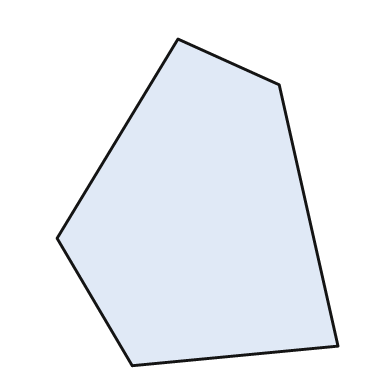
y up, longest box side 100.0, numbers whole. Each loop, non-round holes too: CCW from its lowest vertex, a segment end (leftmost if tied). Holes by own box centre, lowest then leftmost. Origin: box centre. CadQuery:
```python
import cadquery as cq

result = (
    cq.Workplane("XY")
    .moveTo(-20.0, -50.0)
    .lineTo(43.0, -44.0)
    .lineTo(25.0, 36.0)
    .lineTo(-6.0, 50.0)
    .lineTo(-43.0, -11.0)
    .close()
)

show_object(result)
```